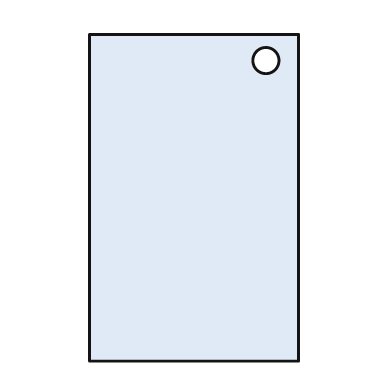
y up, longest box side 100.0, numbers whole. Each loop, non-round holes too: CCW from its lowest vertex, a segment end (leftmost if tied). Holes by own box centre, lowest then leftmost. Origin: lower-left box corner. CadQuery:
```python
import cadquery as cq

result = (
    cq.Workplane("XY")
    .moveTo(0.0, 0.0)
    .lineTo(64.0, 0.0)
    .lineTo(64.0, 100.0)
    .lineTo(0.0, 100.0)
    .close()
    .moveTo(54.0, 92.0)
    .circle(4.0)
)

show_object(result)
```